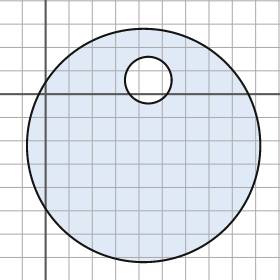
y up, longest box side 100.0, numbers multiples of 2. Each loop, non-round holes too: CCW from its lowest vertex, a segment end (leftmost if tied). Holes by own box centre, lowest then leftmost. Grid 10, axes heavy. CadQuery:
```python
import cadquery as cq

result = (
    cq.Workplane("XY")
    .moveTo(42.0, -22.0)
    .circle(50.0)
    .moveTo(44.0, 6.0)
    .circle(10.0)
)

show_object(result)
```